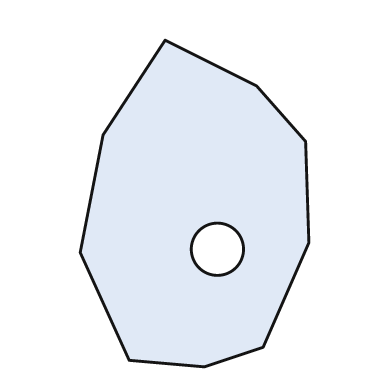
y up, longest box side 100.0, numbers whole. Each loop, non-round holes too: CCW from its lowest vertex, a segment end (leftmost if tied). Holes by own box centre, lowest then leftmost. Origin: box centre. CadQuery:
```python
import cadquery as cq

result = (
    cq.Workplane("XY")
    .moveTo(3.0, -50.0)
    .lineTo(21.0, -44.0)
    .lineTo(35.0, -12.0)
    .lineTo(34.0, 19.0)
    .lineTo(19.0, 36.0)
    .lineTo(-9.0, 50.0)
    .lineTo(-28.0, 21.0)
    .lineTo(-35.0, -15.0)
    .lineTo(-20.0, -48.0)
    .close()
    .moveTo(7.0, -14.0)
    .circle(8.0)
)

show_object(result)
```